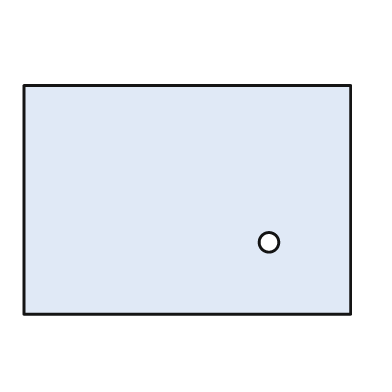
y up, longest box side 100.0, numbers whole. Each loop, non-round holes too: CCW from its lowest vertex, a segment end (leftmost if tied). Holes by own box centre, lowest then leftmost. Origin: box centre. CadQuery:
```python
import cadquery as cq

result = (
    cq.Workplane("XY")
    .moveTo(-50.0, -35.0)
    .lineTo(50.0, -35.0)
    .lineTo(50.0, 35.0)
    .lineTo(-50.0, 35.0)
    .close()
    .moveTo(25.0, -13.0)
    .circle(3.0)
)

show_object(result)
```